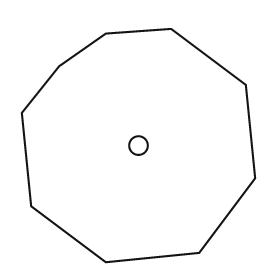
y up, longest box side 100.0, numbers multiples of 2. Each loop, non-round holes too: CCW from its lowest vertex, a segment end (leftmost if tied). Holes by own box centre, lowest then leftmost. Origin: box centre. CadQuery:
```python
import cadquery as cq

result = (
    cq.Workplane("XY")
    .moveTo(-14.0, -50.0)
    .lineTo(26.0, -46.0)
    .lineTo(50.0, -14.0)
    .lineTo(46.0, 26.0)
    .lineTo(14.0, 50.0)
    .lineTo(-14.0, 48.0)
    .lineTo(-34.0, 34.0)
    .lineTo(-50.0, 14.0)
    .lineTo(-46.0, -26.0)
    .close()
    .moveTo(0.0, 0.0)
    .circle(4.0)
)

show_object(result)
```